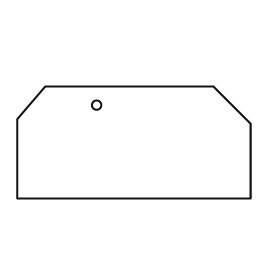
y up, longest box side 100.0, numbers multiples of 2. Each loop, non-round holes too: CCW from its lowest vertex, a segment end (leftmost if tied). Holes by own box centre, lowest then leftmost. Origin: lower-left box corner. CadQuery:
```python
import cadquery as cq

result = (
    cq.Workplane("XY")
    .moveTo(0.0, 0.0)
    .lineTo(100.0, 0.0)
    .lineTo(100.0, 32.0)
    .lineTo(84.0, 48.0)
    .lineTo(12.0, 48.0)
    .lineTo(0.0, 34.0)
    .close()
    .moveTo(34.0, 40.0)
    .circle(2.0)
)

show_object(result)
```